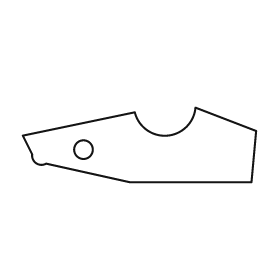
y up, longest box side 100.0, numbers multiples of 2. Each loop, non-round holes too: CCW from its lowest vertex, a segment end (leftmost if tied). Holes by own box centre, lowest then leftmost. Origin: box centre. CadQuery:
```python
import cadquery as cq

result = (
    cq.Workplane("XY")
    .moveTo(-4.0, -16.0)
    .lineTo(48.0, -16.0)
    .lineTo(50.0, 6.0)
    .lineTo(24.0, 16.0)
    .threePointArc((12.0, 4.0), (-2.0, 14.0))
    .lineTo(-50.0, 4.0)
    .lineTo(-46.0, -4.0)
    .threePointArc((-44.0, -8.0), (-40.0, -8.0))
    .close()
    .moveTo(-24.0, -2.0)
    .circle(4.0)
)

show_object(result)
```